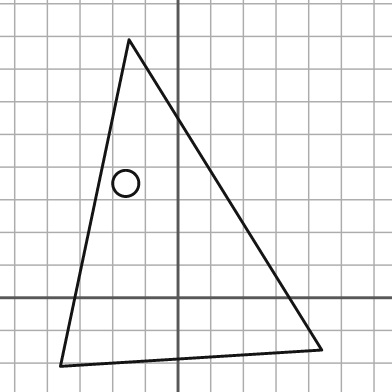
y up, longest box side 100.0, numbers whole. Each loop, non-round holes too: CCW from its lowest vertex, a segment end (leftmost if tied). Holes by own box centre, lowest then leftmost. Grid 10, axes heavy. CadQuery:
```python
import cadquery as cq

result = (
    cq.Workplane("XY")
    .moveTo(-36.0, -21.0)
    .lineTo(44.0, -16.0)
    .lineTo(-15.0, 79.0)
    .close()
    .moveTo(-16.0, 35.0)
    .circle(4.0)
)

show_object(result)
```